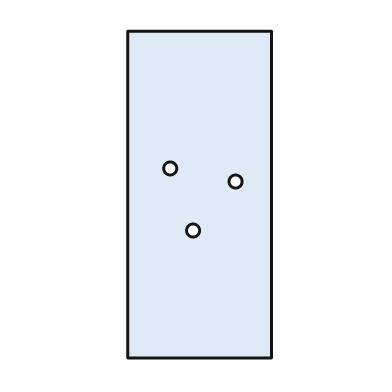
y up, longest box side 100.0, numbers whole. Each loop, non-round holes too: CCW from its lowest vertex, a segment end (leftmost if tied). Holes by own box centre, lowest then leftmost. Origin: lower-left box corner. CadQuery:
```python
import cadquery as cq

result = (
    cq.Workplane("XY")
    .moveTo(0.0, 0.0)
    .lineTo(44.0, 0.0)
    .lineTo(44.0, 100.0)
    .lineTo(0.0, 100.0)
    .close()
    .moveTo(20.0, 39.0)
    .circle(2.0)
    .moveTo(33.0, 54.0)
    .circle(2.0)
    .moveTo(13.0, 58.0)
    .circle(2.0)
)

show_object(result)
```